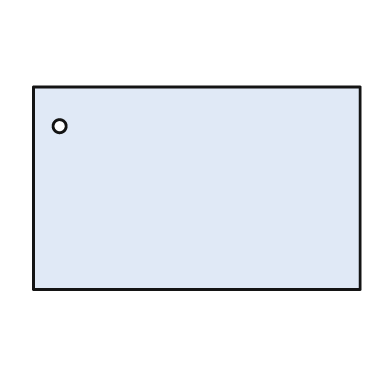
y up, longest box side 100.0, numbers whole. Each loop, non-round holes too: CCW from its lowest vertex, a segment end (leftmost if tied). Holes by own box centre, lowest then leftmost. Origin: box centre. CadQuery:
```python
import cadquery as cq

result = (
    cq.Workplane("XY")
    .moveTo(-50.0, -31.0)
    .lineTo(50.0, -31.0)
    .lineTo(50.0, 31.0)
    .lineTo(-50.0, 31.0)
    .close()
    .moveTo(-42.0, 19.0)
    .circle(2.0)
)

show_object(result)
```